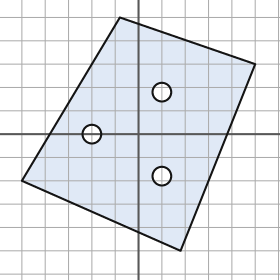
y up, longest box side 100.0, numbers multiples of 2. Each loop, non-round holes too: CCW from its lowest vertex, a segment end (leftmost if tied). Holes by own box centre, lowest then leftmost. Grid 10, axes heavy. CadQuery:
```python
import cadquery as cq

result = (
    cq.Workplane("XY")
    .moveTo(18.0, -50.0)
    .lineTo(50.0, 30.0)
    .lineTo(-8.0, 50.0)
    .lineTo(-50.0, -20.0)
    .close()
    .moveTo(10.0, -18.0)
    .circle(4.0)
    .moveTo(-20.0, 0.0)
    .circle(4.0)
    .moveTo(10.0, 18.0)
    .circle(4.0)
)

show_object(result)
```